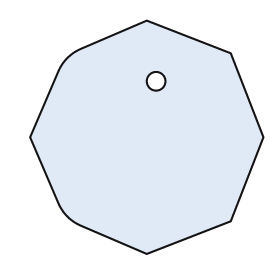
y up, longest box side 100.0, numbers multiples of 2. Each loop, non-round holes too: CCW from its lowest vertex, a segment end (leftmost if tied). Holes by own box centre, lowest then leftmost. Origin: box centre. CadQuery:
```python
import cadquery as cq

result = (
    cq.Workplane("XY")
    .moveTo(0.0, -50.0)
    .lineTo(36.0, -36.0)
    .lineTo(50.0, 0.0)
    .lineTo(36.0, 36.0)
    .lineTo(0.0, 50.0)
    .lineTo(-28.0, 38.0)
    .threePointArc((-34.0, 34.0), (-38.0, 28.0))
    .lineTo(-50.0, 0.0)
    .lineTo(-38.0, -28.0)
    .threePointArc((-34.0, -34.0), (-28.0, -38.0))
    .close()
    .moveTo(4.0, 24.0)
    .circle(4.0)
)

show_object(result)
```